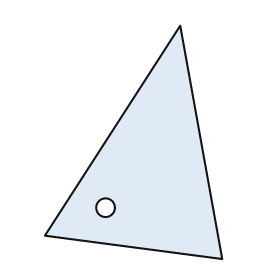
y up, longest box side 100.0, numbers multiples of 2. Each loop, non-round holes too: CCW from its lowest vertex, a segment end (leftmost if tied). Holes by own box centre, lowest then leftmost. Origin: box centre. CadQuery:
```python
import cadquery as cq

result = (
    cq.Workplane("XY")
    .moveTo(38.0, -50.0)
    .lineTo(20.0, 50.0)
    .lineTo(-38.0, -40.0)
    .close()
    .moveTo(-12.0, -28.0)
    .circle(4.0)
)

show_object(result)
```